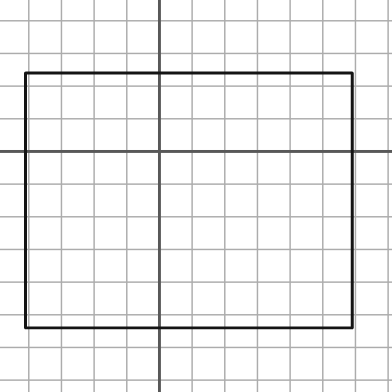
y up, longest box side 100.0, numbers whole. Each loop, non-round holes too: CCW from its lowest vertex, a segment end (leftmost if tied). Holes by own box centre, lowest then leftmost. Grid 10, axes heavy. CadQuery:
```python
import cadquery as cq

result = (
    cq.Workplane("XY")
    .moveTo(-41.0, -54.0)
    .lineTo(59.0, -54.0)
    .lineTo(59.0, 24.0)
    .lineTo(-41.0, 24.0)
    .close()
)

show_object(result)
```